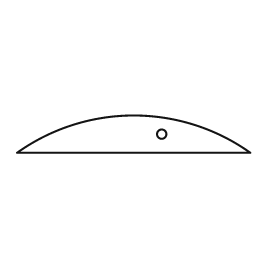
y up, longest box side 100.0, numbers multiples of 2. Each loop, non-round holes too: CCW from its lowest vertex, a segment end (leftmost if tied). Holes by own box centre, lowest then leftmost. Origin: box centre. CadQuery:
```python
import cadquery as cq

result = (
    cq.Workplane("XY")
    .moveTo(-50.0, -8.0)
    .lineTo(50.0, -8.0)
    .threePointArc((0.0, 8.0), (-50.0, -8.0))
    .close()
    .moveTo(12.0, 0.0)
    .circle(2.0)
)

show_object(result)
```